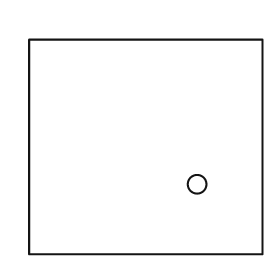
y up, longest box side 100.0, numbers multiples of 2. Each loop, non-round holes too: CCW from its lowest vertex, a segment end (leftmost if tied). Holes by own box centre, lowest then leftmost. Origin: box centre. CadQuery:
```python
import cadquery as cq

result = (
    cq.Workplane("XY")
    .moveTo(-50.0, -46.0)
    .lineTo(50.0, -46.0)
    .lineTo(50.0, 46.0)
    .lineTo(-50.0, 46.0)
    .close()
    .moveTo(22.0, -16.0)
    .circle(4.0)
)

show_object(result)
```